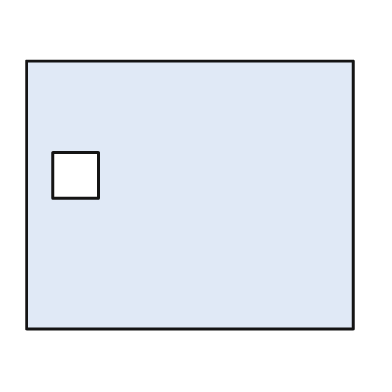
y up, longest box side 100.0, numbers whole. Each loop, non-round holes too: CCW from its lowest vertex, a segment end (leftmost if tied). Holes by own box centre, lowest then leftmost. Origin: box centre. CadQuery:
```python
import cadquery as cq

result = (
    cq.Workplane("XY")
    .moveTo(-50.0, -41.0)
    .lineTo(50.0, -41.0)
    .lineTo(50.0, 41.0)
    .lineTo(-50.0, 41.0)
    .close()
    .moveTo(-42.0, -1.0)
    .lineTo(-28.0, -1.0)
    .lineTo(-28.0, 13.0)
    .lineTo(-42.0, 13.0)
    .close()
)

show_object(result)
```